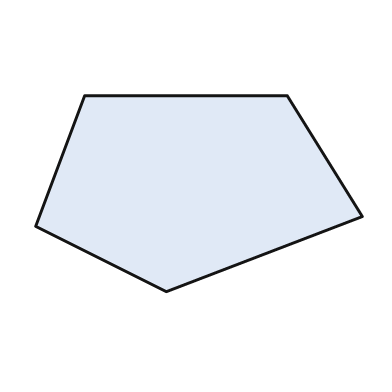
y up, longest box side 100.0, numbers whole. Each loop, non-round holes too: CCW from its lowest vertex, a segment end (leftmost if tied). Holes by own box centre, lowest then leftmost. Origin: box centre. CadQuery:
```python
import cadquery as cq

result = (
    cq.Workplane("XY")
    .moveTo(-10.0, -30.0)
    .lineTo(50.0, -7.0)
    .lineTo(27.0, 30.0)
    .lineTo(-35.0, 30.0)
    .lineTo(-50.0, -10.0)
    .close()
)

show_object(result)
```